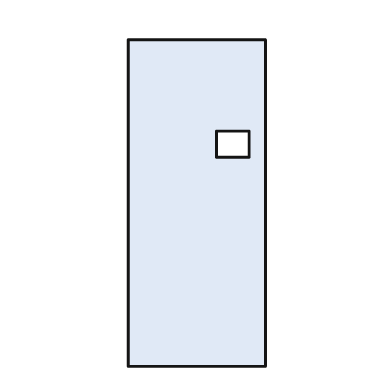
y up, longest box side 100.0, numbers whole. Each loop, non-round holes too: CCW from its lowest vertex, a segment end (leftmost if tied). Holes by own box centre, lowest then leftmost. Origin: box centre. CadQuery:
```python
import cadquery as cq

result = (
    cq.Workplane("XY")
    .moveTo(-21.0, -50.0)
    .lineTo(21.0, -50.0)
    .lineTo(21.0, 50.0)
    .lineTo(-21.0, 50.0)
    .close()
    .moveTo(6.0, 14.0)
    .lineTo(16.0, 14.0)
    .lineTo(16.0, 22.0)
    .lineTo(6.0, 22.0)
    .close()
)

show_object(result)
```